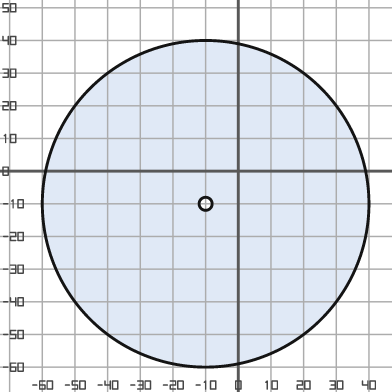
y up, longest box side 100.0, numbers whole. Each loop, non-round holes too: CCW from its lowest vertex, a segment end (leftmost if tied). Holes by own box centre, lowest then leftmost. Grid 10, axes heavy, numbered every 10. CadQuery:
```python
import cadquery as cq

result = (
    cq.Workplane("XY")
    .moveTo(-10.0, -10.0)
    .circle(50.0)
    .moveTo(-10.0, -10.0)
    .circle(2.0)
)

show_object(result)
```